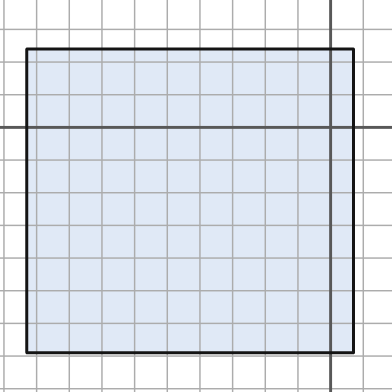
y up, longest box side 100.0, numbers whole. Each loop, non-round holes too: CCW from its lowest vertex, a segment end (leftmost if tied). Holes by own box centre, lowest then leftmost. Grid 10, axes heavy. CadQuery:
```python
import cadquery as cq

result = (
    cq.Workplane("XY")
    .moveTo(-93.0, -69.0)
    .lineTo(7.0, -69.0)
    .lineTo(7.0, 24.0)
    .lineTo(-93.0, 24.0)
    .close()
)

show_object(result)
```